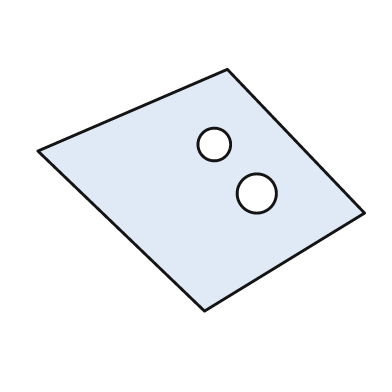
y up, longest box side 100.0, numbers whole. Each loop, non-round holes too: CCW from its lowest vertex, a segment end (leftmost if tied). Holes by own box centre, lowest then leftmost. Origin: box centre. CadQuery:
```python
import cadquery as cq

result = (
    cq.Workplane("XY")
    .moveTo(1.0, -37.0)
    .lineTo(50.0, -7.0)
    .lineTo(8.0, 37.0)
    .lineTo(-50.0, 12.0)
    .close()
    .moveTo(17.0, -1.0)
    .circle(6.0)
    .moveTo(4.0, 14.0)
    .circle(5.0)
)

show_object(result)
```